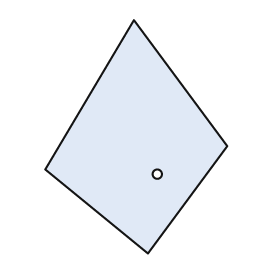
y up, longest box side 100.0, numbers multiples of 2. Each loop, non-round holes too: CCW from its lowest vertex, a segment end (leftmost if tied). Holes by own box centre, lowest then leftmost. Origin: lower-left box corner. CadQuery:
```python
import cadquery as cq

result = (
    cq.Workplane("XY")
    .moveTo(44.0, 0.0)
    .lineTo(78.0, 46.0)
    .lineTo(38.0, 100.0)
    .lineTo(0.0, 36.0)
    .close()
    .moveTo(48.0, 34.0)
    .circle(2.0)
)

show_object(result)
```